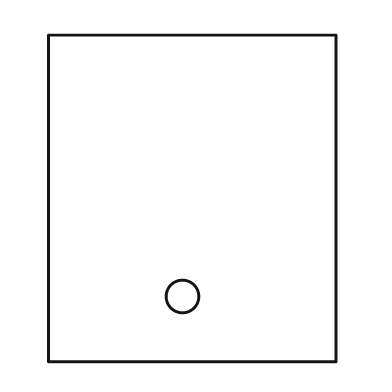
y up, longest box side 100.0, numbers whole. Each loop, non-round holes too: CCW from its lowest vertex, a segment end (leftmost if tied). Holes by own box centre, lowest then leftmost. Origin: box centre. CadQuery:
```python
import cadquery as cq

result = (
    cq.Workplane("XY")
    .moveTo(-44.0, -50.0)
    .lineTo(44.0, -50.0)
    .lineTo(44.0, 50.0)
    .lineTo(-44.0, 50.0)
    .close()
    .moveTo(-3.0, -30.0)
    .circle(5.0)
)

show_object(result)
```